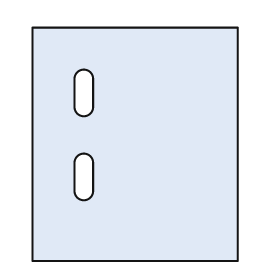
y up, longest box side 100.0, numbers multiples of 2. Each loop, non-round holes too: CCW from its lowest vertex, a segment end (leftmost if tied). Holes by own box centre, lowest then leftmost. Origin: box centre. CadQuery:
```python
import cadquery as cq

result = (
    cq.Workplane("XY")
    .moveTo(-44.0, -50.0)
    .lineTo(44.0, -50.0)
    .lineTo(44.0, 50.0)
    .lineTo(-44.0, 50.0)
    .close()
    .moveTo(-26.0, -20.0)
    .threePointArc((-22.0, -24.0), (-18.0, -20.0))
    .lineTo(-18.0, -8.0)
    .threePointArc((-22.0, -4.0), (-26.0, -8.0))
    .close()
    .moveTo(-26.0, 16.0)
    .threePointArc((-22.0, 12.0), (-18.0, 16.0))
    .lineTo(-18.0, 28.0)
    .threePointArc((-22.0, 32.0), (-26.0, 28.0))
    .close()
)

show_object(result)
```